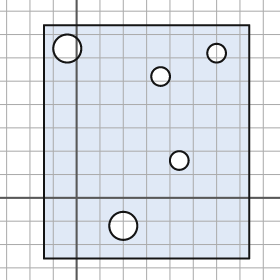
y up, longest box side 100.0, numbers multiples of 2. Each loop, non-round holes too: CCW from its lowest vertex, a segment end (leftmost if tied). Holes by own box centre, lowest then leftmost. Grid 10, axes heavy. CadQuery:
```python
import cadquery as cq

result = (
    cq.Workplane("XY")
    .moveTo(-14.0, -26.0)
    .lineTo(74.0, -26.0)
    .lineTo(74.0, 74.0)
    .lineTo(-14.0, 74.0)
    .close()
    .moveTo(20.0, -12.0)
    .circle(6.0)
    .moveTo(44.0, 16.0)
    .circle(4.0)
    .moveTo(36.0, 52.0)
    .circle(4.0)
    .moveTo(60.0, 62.0)
    .circle(4.0)
    .moveTo(-4.0, 64.0)
    .circle(6.0)
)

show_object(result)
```